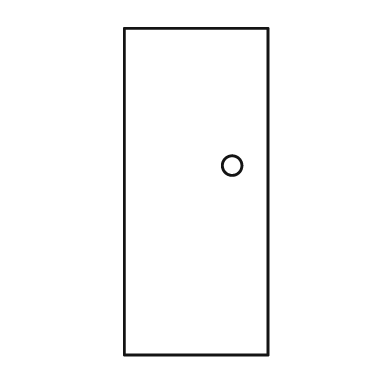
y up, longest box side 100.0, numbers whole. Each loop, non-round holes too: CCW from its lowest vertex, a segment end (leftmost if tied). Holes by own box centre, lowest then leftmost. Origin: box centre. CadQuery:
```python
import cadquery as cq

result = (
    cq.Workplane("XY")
    .moveTo(-22.0, -50.0)
    .lineTo(22.0, -50.0)
    .lineTo(22.0, 50.0)
    .lineTo(-22.0, 50.0)
    .close()
    .moveTo(11.0, 8.0)
    .circle(3.0)
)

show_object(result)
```